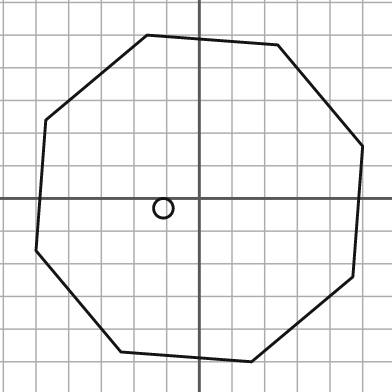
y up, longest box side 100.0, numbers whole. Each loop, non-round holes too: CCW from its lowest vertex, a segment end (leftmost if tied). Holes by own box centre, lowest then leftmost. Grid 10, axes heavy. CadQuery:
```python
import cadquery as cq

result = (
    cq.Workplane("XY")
    .moveTo(16.0, -50.0)
    .lineTo(47.0, -24.0)
    .lineTo(50.0, 16.0)
    .lineTo(24.0, 47.0)
    .lineTo(-16.0, 50.0)
    .lineTo(-47.0, 24.0)
    .lineTo(-50.0, -16.0)
    .lineTo(-24.0, -47.0)
    .close()
    .moveTo(-11.0, -3.0)
    .circle(3.0)
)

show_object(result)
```